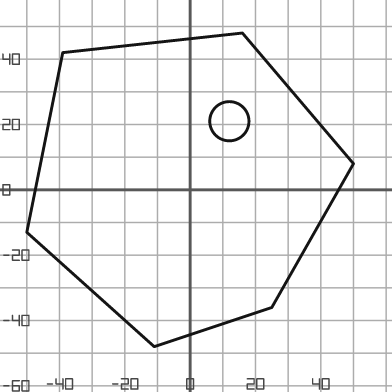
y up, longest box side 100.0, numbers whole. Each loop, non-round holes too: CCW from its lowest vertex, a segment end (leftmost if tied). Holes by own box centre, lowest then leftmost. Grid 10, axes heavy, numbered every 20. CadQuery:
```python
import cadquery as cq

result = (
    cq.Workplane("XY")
    .moveTo(-11.0, -48.0)
    .lineTo(25.0, -36.0)
    .lineTo(50.0, 8.0)
    .lineTo(16.0, 48.0)
    .lineTo(-39.0, 42.0)
    .lineTo(-50.0, -13.0)
    .close()
    .moveTo(12.0, 21.0)
    .circle(6.0)
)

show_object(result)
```